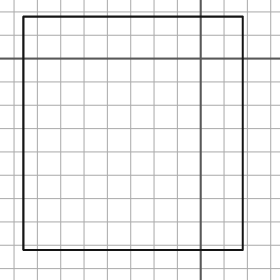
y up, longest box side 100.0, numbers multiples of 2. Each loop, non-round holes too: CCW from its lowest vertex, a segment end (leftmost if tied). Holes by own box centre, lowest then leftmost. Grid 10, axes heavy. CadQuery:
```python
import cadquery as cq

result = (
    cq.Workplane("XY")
    .moveTo(-76.0, -82.0)
    .lineTo(18.0, -82.0)
    .lineTo(18.0, 18.0)
    .lineTo(-76.0, 18.0)
    .close()
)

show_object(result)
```